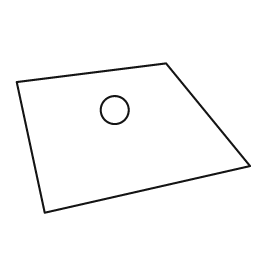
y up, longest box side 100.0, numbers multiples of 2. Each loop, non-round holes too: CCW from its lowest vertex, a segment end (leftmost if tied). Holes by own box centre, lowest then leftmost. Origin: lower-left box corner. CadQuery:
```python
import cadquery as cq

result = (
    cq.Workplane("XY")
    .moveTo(12.0, 0.0)
    .lineTo(100.0, 20.0)
    .lineTo(64.0, 64.0)
    .lineTo(0.0, 56.0)
    .close()
    .moveTo(42.0, 44.0)
    .circle(6.0)
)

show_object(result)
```